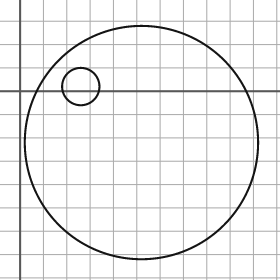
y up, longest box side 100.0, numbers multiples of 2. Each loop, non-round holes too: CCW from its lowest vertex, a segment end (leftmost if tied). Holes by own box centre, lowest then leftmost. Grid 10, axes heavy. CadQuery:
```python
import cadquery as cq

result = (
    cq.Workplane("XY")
    .moveTo(52.0, -22.0)
    .circle(50.0)
    .moveTo(26.0, 2.0)
    .circle(8.0)
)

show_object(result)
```